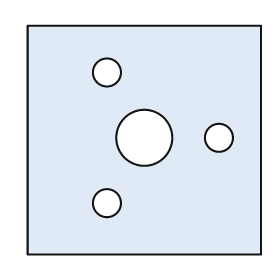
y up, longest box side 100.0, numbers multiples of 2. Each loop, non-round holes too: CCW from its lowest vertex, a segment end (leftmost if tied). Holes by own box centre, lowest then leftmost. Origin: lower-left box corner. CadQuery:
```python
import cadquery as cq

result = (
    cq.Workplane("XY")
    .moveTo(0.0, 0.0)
    .lineTo(100.0, 0.0)
    .lineTo(100.0, 98.0)
    .lineTo(0.0, 98.0)
    .close()
    .moveTo(34.0, 22.0)
    .circle(6.0)
    .moveTo(50.0, 50.0)
    .circle(12.0)
    .moveTo(82.0, 50.0)
    .circle(6.0)
    .moveTo(34.0, 78.0)
    .circle(6.0)
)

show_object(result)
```